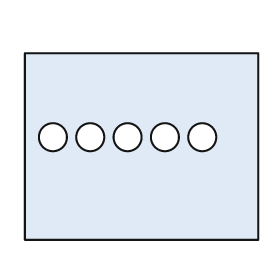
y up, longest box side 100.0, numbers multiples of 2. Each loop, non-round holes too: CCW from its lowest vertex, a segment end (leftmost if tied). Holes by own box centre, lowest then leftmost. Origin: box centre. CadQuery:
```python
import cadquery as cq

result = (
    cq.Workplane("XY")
    .moveTo(-50.0, -40.0)
    .lineTo(50.0, -40.0)
    .lineTo(50.0, 40.0)
    .lineTo(-50.0, 40.0)
    .close()
    .moveTo(-38.0, 4.0)
    .circle(6.0)
    .moveTo(-22.0, 4.0)
    .circle(6.0)
    .moveTo(-6.0, 4.0)
    .circle(6.0)
    .moveTo(10.0, 4.0)
    .circle(6.0)
    .moveTo(26.0, 4.0)
    .circle(6.0)
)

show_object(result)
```